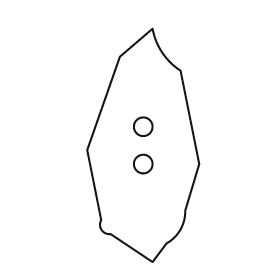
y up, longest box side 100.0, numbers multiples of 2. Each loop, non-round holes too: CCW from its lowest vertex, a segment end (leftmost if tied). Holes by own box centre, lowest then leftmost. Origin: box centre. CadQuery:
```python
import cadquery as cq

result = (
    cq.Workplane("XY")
    .moveTo(4.0, -50.0)
    .lineTo(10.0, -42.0)
    .threePointArc((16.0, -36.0), (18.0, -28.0))
    .lineTo(24.0, -8.0)
    .lineTo(16.0, 32.0)
    .threePointArc((8.0, 40.0), (4.0, 50.0))
    .lineTo(-10.0, 38.0)
    .lineTo(-24.0, -2.0)
    .lineTo(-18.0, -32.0)
    .threePointArc((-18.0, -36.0), (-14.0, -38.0))
    .close()
    .moveTo(0.0, -8.0)
    .circle(4.0)
    .moveTo(0.0, 8.0)
    .circle(4.0)
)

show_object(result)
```